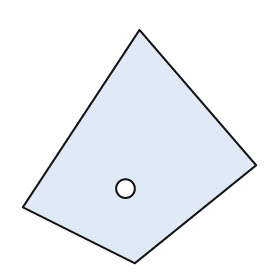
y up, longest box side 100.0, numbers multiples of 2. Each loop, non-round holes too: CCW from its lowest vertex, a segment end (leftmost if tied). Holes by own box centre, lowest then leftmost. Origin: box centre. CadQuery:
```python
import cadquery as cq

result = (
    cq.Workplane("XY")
    .moveTo(-2.0, -50.0)
    .lineTo(50.0, -8.0)
    .lineTo(0.0, 50.0)
    .lineTo(-50.0, -26.0)
    .close()
    .moveTo(-6.0, -18.0)
    .circle(4.0)
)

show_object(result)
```